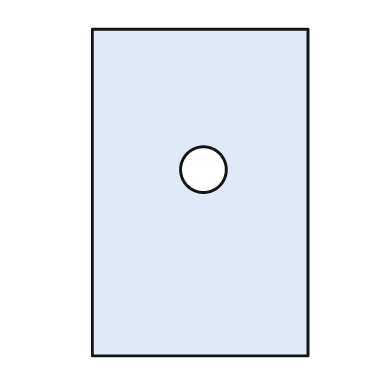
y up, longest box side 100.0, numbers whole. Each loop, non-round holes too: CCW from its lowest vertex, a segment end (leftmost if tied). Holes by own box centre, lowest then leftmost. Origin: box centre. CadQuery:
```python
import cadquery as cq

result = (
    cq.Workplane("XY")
    .moveTo(-33.0, -50.0)
    .lineTo(33.0, -50.0)
    .lineTo(33.0, 50.0)
    .lineTo(-33.0, 50.0)
    .close()
    .moveTo(1.0, 7.0)
    .circle(7.0)
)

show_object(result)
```